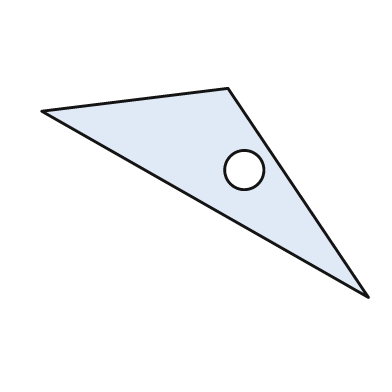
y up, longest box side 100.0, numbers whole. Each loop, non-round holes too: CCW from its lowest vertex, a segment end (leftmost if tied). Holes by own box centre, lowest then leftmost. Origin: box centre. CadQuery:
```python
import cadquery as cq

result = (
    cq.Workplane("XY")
    .moveTo(50.0, -32.0)
    .lineTo(7.0, 32.0)
    .lineTo(-50.0, 25.0)
    .close()
    .moveTo(12.0, 7.0)
    .circle(6.0)
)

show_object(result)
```